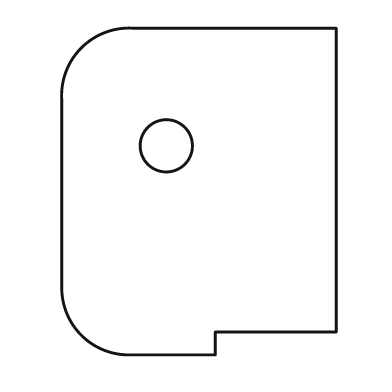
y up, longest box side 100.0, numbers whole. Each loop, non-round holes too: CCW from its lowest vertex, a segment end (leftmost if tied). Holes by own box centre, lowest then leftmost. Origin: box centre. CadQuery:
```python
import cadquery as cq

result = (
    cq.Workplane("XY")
    .moveTo(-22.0, -50.0)
    .lineTo(5.0, -50.0)
    .lineTo(5.0, -43.0)
    .lineTo(42.0, -43.0)
    .lineTo(42.0, 50.0)
    .lineTo(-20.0, 50.0)
    .threePointArc((-36.0, 44.0), (-42.0, 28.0))
    .lineTo(-42.0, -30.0)
    .threePointArc((-36.0, -44.0), (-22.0, -50.0))
    .close()
    .moveTo(-10.0, 14.0)
    .circle(8.0)
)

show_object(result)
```